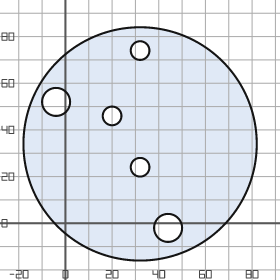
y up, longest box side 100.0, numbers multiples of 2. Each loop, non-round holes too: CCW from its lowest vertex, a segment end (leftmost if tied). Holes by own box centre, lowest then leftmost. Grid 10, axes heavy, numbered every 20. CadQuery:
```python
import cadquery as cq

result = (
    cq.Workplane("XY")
    .moveTo(32.0, 34.0)
    .circle(50.0)
    .moveTo(44.0, -2.0)
    .circle(6.0)
    .moveTo(32.0, 24.0)
    .circle(4.0)
    .moveTo(20.0, 46.0)
    .circle(4.0)
    .moveTo(-4.0, 52.0)
    .circle(6.0)
    .moveTo(32.0, 74.0)
    .circle(4.0)
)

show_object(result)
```